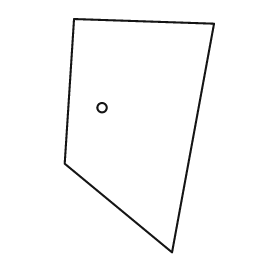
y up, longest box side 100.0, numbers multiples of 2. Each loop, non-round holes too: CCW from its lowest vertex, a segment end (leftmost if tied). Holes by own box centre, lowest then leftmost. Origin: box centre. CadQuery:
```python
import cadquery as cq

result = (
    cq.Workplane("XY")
    .moveTo(14.0, -50.0)
    .lineTo(32.0, 48.0)
    .lineTo(-28.0, 50.0)
    .lineTo(-32.0, -12.0)
    .close()
    .moveTo(-16.0, 12.0)
    .circle(2.0)
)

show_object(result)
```